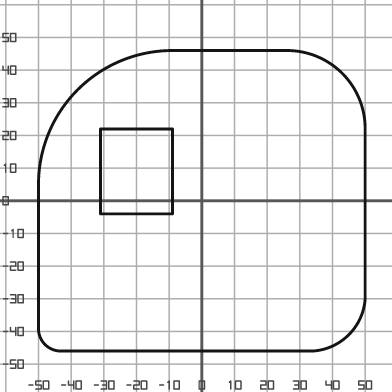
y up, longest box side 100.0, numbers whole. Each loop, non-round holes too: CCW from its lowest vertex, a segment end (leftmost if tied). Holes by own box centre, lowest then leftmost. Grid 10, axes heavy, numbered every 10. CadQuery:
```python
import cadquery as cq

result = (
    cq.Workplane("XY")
    .moveTo(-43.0, -46.0)
    .lineTo(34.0, -46.0)
    .threePointArc((45.0, -41.0), (50.0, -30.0))
    .lineTo(50.0, 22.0)
    .threePointArc((43.0, 39.0), (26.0, 46.0))
    .lineTo(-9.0, 46.0)
    .threePointArc((-38.0, 34.0), (-50.0, 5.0))
    .lineTo(-50.0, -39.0)
    .threePointArc((-48.0, -44.0), (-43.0, -46.0))
    .close()
    .moveTo(-31.0, -4.0)
    .lineTo(-9.0, -4.0)
    .lineTo(-9.0, 22.0)
    .lineTo(-31.0, 22.0)
    .close()
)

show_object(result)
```